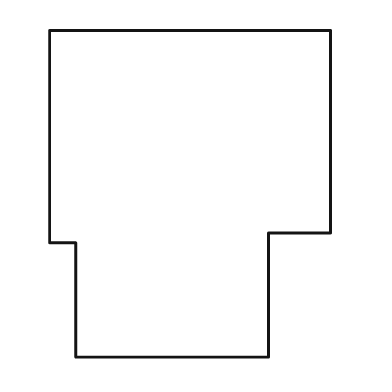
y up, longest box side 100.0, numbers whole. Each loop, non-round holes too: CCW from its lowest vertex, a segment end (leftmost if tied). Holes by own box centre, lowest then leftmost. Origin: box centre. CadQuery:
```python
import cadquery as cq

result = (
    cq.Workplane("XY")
    .moveTo(-35.0, -50.0)
    .lineTo(24.0, -50.0)
    .lineTo(24.0, -12.0)
    .lineTo(43.0, -12.0)
    .lineTo(43.0, 50.0)
    .lineTo(-43.0, 50.0)
    .lineTo(-43.0, -15.0)
    .lineTo(-35.0, -15.0)
    .close()
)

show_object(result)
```